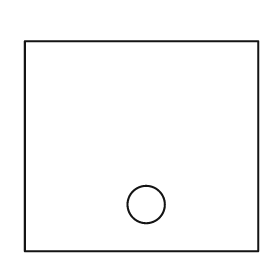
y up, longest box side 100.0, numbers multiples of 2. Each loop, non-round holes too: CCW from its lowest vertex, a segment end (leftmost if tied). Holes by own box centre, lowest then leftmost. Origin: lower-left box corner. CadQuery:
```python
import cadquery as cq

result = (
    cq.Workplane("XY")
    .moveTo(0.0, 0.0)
    .lineTo(100.0, 0.0)
    .lineTo(100.0, 90.0)
    .lineTo(0.0, 90.0)
    .close()
    .moveTo(52.0, 20.0)
    .circle(8.0)
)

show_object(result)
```